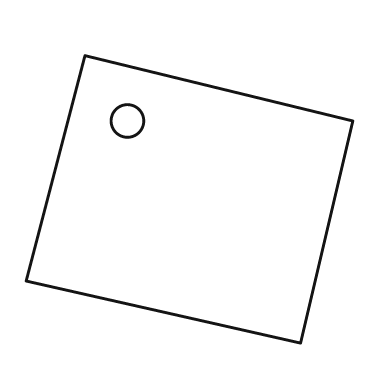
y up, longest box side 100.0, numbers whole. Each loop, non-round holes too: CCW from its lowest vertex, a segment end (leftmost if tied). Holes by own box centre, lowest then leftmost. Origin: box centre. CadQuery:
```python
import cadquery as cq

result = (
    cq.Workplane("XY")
    .moveTo(34.0, -44.0)
    .lineTo(50.0, 24.0)
    .lineTo(-32.0, 44.0)
    .lineTo(-50.0, -25.0)
    .close()
    .moveTo(-19.0, 24.0)
    .circle(5.0)
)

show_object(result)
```